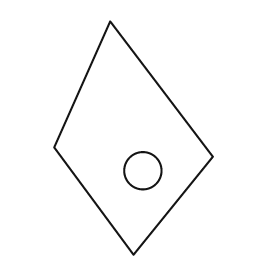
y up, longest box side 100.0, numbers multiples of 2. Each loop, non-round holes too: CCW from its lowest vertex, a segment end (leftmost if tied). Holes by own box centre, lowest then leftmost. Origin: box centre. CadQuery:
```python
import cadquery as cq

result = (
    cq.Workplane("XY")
    .moveTo(0.0, -50.0)
    .lineTo(34.0, -8.0)
    .lineTo(-10.0, 50.0)
    .lineTo(-34.0, -4.0)
    .close()
    .moveTo(4.0, -14.0)
    .circle(8.0)
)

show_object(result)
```